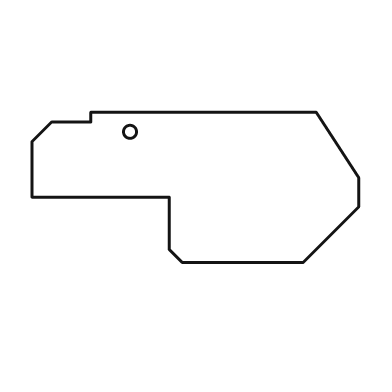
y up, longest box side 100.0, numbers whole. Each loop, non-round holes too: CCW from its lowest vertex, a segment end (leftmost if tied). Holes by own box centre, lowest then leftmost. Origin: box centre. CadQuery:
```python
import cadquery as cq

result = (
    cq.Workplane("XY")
    .moveTo(-4.0, -23.0)
    .lineTo(33.0, -23.0)
    .lineTo(50.0, -6.0)
    .lineTo(50.0, 3.0)
    .lineTo(37.0, 23.0)
    .lineTo(-32.0, 23.0)
    .lineTo(-32.0, 20.0)
    .lineTo(-44.0, 20.0)
    .lineTo(-50.0, 14.0)
    .lineTo(-50.0, -3.0)
    .lineTo(-8.0, -3.0)
    .lineTo(-8.0, -19.0)
    .close()
    .moveTo(-20.0, 17.0)
    .circle(2.0)
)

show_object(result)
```